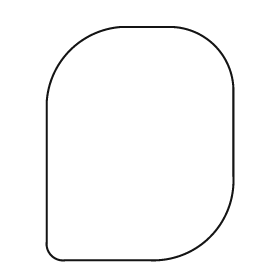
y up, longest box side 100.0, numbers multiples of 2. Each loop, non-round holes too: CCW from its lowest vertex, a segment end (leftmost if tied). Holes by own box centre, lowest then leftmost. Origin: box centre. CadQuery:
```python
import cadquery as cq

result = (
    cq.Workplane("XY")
    .moveTo(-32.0, -50.0)
    .lineTo(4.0, -50.0)
    .threePointArc((30.0, -40.0), (40.0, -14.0))
    .lineTo(40.0, 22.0)
    .threePointArc((32.0, 42.0), (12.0, 50.0))
    .lineTo(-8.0, 50.0)
    .threePointArc((-30.0, 40.0), (-40.0, 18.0))
    .lineTo(-40.0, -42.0)
    .threePointArc((-38.0, -48.0), (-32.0, -50.0))
    .close()
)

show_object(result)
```